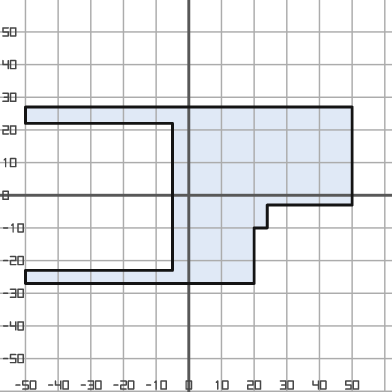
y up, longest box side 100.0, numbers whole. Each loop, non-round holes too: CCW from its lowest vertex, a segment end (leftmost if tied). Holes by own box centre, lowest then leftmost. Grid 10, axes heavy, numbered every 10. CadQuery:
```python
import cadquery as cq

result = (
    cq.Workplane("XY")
    .moveTo(-50.0, -27.0)
    .lineTo(20.0, -27.0)
    .lineTo(20.0, -10.0)
    .lineTo(24.0, -10.0)
    .lineTo(24.0, -3.0)
    .lineTo(50.0, -3.0)
    .lineTo(50.0, 27.0)
    .lineTo(-50.0, 27.0)
    .lineTo(-50.0, 22.0)
    .lineTo(-5.0, 22.0)
    .lineTo(-5.0, -23.0)
    .lineTo(-50.0, -23.0)
    .close()
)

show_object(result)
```